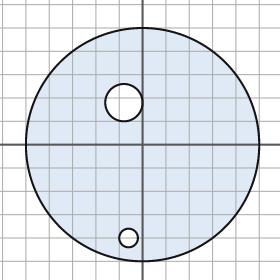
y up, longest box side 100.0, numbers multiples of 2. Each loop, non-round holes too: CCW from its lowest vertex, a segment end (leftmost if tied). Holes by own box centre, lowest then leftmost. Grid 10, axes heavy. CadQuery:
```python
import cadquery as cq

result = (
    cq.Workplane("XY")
    .moveTo(0.0, 0.0)
    .circle(50.0)
    .moveTo(-6.0, -40.0)
    .circle(4.0)
    .moveTo(-8.0, 18.0)
    .circle(8.0)
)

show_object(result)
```